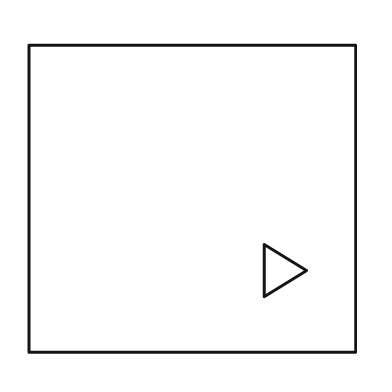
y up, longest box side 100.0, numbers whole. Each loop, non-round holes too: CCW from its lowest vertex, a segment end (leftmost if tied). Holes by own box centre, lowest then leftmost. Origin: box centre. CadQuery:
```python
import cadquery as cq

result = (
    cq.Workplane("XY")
    .moveTo(-50.0, -47.0)
    .lineTo(50.0, -47.0)
    .lineTo(50.0, 47.0)
    .lineTo(-50.0, 47.0)
    .close()
    .moveTo(22.0, -30.0)
    .lineTo(35.0, -22.0)
    .lineTo(22.0, -14.0)
    .close()
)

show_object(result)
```